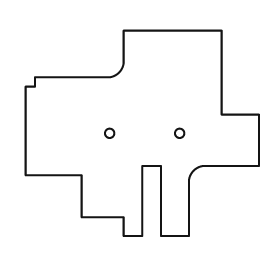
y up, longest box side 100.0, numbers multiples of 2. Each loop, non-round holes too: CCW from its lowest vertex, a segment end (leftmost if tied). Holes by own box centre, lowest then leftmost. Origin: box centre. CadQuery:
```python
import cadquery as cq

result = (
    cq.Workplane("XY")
    .moveTo(-8.0, -44.0)
    .lineTo(0.0, -44.0)
    .lineTo(0.0, -14.0)
    .lineTo(8.0, -14.0)
    .lineTo(8.0, -44.0)
    .lineTo(20.0, -44.0)
    .lineTo(20.0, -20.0)
    .threePointArc((22.0, -16.0), (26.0, -14.0))
    .lineTo(50.0, -14.0)
    .lineTo(50.0, 8.0)
    .lineTo(34.0, 8.0)
    .lineTo(34.0, 44.0)
    .lineTo(-8.0, 44.0)
    .lineTo(-8.0, 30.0)
    .threePointArc((-10.0, 26.0), (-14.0, 24.0))
    .lineTo(-46.0, 24.0)
    .lineTo(-46.0, 20.0)
    .lineTo(-50.0, 20.0)
    .lineTo(-50.0, -18.0)
    .lineTo(-26.0, -18.0)
    .lineTo(-26.0, -36.0)
    .lineTo(-8.0, -36.0)
    .close()
    .moveTo(-14.0, 0.0)
    .circle(2.0)
    .moveTo(16.0, 0.0)
    .circle(2.0)
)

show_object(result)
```